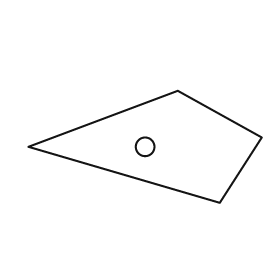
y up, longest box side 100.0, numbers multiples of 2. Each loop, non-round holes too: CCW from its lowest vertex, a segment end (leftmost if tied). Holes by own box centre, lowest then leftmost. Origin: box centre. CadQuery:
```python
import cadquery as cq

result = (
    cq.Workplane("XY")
    .moveTo(32.0, -24.0)
    .lineTo(50.0, 4.0)
    .lineTo(14.0, 24.0)
    .lineTo(-50.0, 0.0)
    .close()
    .moveTo(0.0, 0.0)
    .circle(4.0)
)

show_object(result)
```